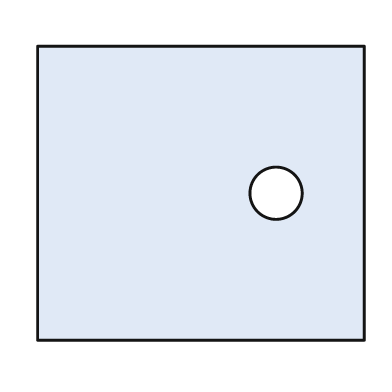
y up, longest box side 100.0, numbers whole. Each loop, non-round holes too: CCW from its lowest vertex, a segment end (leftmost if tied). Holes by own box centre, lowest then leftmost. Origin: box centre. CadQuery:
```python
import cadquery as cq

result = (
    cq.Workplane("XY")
    .moveTo(-50.0, -45.0)
    .lineTo(50.0, -45.0)
    .lineTo(50.0, 45.0)
    .lineTo(-50.0, 45.0)
    .close()
    .moveTo(23.0, 0.0)
    .circle(8.0)
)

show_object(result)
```